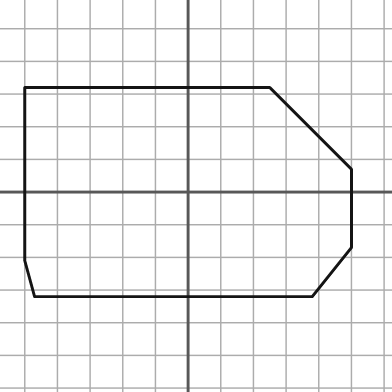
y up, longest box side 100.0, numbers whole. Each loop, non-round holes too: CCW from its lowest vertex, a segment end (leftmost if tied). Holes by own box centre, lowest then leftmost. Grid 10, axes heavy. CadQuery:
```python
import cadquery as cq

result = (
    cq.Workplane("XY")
    .moveTo(-47.0, -32.0)
    .lineTo(38.0, -32.0)
    .lineTo(50.0, -17.0)
    .lineTo(50.0, 7.0)
    .lineTo(25.0, 32.0)
    .lineTo(-50.0, 32.0)
    .lineTo(-50.0, -21.0)
    .close()
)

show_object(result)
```